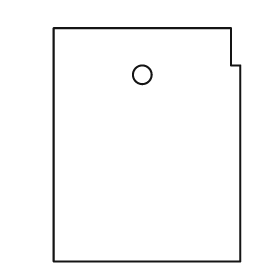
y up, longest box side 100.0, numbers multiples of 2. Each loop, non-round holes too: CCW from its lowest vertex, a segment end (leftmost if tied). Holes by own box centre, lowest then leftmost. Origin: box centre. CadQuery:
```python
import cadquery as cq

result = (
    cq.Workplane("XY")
    .moveTo(-40.0, -50.0)
    .lineTo(40.0, -50.0)
    .lineTo(40.0, 34.0)
    .lineTo(36.0, 34.0)
    .lineTo(36.0, 50.0)
    .lineTo(-40.0, 50.0)
    .close()
    .moveTo(-2.0, 30.0)
    .circle(4.0)
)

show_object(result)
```